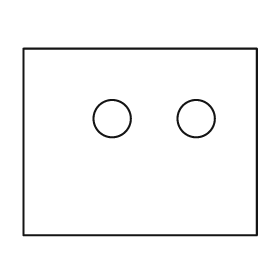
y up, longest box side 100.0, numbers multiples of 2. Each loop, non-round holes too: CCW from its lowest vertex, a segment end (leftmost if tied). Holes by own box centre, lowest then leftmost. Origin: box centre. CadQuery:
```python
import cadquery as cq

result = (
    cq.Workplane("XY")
    .moveTo(-50.0, -40.0)
    .lineTo(50.0, -40.0)
    .lineTo(50.0, 40.0)
    .lineTo(-50.0, 40.0)
    .close()
    .moveTo(-12.0, 10.0)
    .circle(8.0)
    .moveTo(24.0, 10.0)
    .circle(8.0)
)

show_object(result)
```